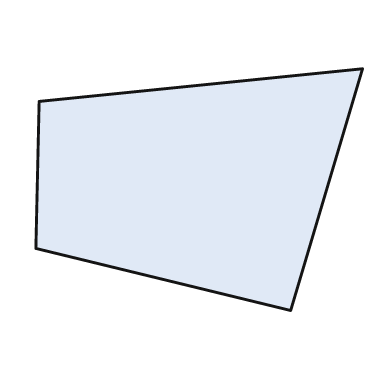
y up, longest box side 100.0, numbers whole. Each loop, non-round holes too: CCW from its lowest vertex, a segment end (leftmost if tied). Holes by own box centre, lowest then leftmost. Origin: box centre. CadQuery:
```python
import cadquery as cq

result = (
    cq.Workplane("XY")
    .moveTo(28.0, -37.0)
    .lineTo(50.0, 37.0)
    .lineTo(-49.0, 27.0)
    .lineTo(-50.0, -18.0)
    .close()
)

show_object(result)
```